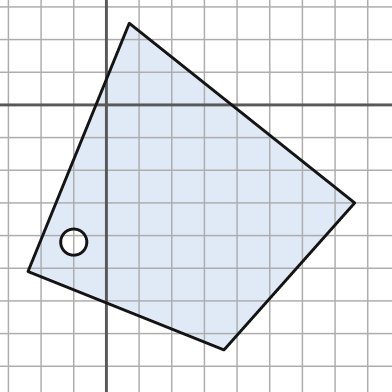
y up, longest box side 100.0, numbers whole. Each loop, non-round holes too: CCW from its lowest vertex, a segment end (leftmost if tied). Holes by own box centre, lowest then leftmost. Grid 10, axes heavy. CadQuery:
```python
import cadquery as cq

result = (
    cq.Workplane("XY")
    .moveTo(36.0, -75.0)
    .lineTo(76.0, -30.0)
    .lineTo(7.0, 25.0)
    .lineTo(-24.0, -51.0)
    .close()
    .moveTo(-10.0, -42.0)
    .circle(4.0)
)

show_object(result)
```